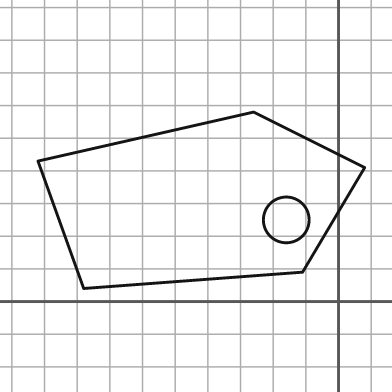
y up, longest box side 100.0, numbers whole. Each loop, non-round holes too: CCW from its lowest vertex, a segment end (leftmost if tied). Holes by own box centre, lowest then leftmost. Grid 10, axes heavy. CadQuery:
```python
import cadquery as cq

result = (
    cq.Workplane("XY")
    .moveTo(-78.0, 4.0)
    .lineTo(-11.0, 9.0)
    .lineTo(8.0, 41.0)
    .lineTo(-26.0, 58.0)
    .lineTo(-92.0, 43.0)
    .close()
    .moveTo(-16.0, 25.0)
    .circle(7.0)
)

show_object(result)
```